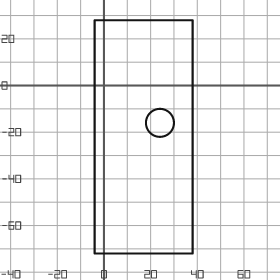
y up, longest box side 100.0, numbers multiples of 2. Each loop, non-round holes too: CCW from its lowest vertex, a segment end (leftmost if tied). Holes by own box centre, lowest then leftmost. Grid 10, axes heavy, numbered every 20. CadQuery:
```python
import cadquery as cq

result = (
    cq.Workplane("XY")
    .moveTo(-4.0, -72.0)
    .lineTo(38.0, -72.0)
    .lineTo(38.0, 28.0)
    .lineTo(-4.0, 28.0)
    .close()
    .moveTo(24.0, -16.0)
    .circle(6.0)
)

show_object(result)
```